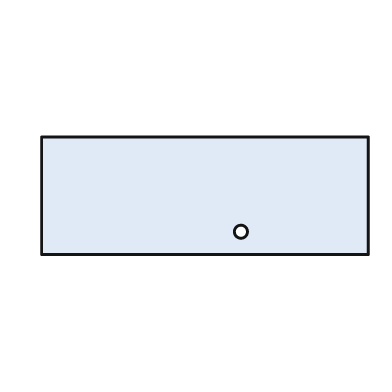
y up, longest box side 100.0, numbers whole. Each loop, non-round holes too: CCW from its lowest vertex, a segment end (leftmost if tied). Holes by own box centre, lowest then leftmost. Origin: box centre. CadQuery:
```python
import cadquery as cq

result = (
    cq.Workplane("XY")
    .moveTo(-50.0, -18.0)
    .lineTo(50.0, -18.0)
    .lineTo(50.0, 18.0)
    .lineTo(-50.0, 18.0)
    .close()
    .moveTo(11.0, -11.0)
    .circle(2.0)
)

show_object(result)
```